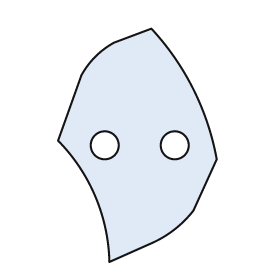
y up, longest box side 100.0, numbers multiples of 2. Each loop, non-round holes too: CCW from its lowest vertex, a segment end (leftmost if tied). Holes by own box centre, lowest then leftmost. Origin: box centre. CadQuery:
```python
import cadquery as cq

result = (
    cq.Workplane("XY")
    .moveTo(-12.0, -50.0)
    .lineTo(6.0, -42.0)
    .threePointArc((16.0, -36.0), (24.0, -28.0))
    .lineTo(34.0, -6.0)
    .threePointArc((24.0, 24.0), (6.0, 50.0))
    .lineTo(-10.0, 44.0)
    .threePointArc((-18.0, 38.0), (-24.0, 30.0))
    .lineTo(-34.0, 2.0)
    .threePointArc((-18.0, -22.0), (-12.0, -50.0))
    .close()
    .moveTo(-14.0, 0.0)
    .circle(6.0)
    .moveTo(16.0, 0.0)
    .circle(6.0)
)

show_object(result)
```